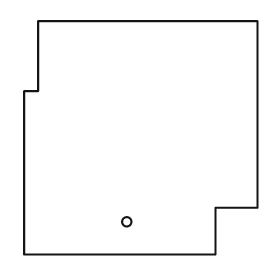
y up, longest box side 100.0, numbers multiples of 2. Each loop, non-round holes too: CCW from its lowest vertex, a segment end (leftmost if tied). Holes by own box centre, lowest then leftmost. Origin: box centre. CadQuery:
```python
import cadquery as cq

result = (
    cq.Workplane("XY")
    .moveTo(-50.0, -50.0)
    .lineTo(32.0, -50.0)
    .lineTo(32.0, -30.0)
    .lineTo(50.0, -30.0)
    .lineTo(50.0, 50.0)
    .lineTo(-44.0, 50.0)
    .lineTo(-44.0, 20.0)
    .lineTo(-50.0, 20.0)
    .close()
    .moveTo(-6.0, -36.0)
    .circle(2.0)
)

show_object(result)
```